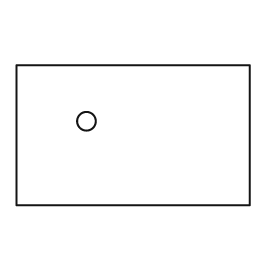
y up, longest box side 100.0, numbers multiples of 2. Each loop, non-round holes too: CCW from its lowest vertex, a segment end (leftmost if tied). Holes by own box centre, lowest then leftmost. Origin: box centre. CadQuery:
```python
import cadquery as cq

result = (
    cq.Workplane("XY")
    .moveTo(-50.0, -30.0)
    .lineTo(50.0, -30.0)
    .lineTo(50.0, 30.0)
    .lineTo(-50.0, 30.0)
    .close()
    .moveTo(-20.0, 6.0)
    .circle(4.0)
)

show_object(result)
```